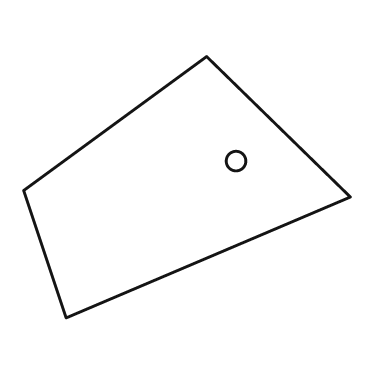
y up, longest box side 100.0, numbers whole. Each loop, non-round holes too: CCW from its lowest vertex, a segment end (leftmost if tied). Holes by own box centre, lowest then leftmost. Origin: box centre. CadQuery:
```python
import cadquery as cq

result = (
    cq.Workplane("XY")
    .moveTo(-37.0, -40.0)
    .lineTo(50.0, -3.0)
    .lineTo(6.0, 40.0)
    .lineTo(-50.0, -1.0)
    .close()
    .moveTo(15.0, 8.0)
    .circle(3.0)
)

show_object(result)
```